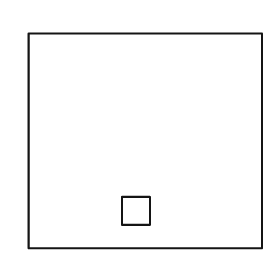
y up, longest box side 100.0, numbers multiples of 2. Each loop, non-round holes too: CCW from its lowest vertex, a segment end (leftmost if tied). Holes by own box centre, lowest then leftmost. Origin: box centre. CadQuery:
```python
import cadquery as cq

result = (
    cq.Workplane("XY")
    .moveTo(-50.0, -46.0)
    .lineTo(50.0, -46.0)
    .lineTo(50.0, 46.0)
    .lineTo(-50.0, 46.0)
    .close()
    .moveTo(-10.0, -36.0)
    .lineTo(2.0, -36.0)
    .lineTo(2.0, -24.0)
    .lineTo(-10.0, -24.0)
    .close()
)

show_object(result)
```